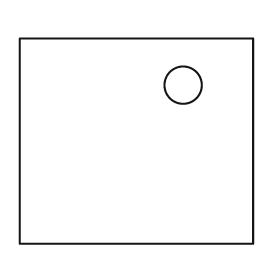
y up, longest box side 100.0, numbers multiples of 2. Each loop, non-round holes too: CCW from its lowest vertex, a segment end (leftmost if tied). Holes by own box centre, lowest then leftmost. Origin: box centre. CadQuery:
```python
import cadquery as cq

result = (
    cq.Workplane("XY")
    .moveTo(-50.0, -44.0)
    .lineTo(50.0, -44.0)
    .lineTo(50.0, 44.0)
    .lineTo(-50.0, 44.0)
    .close()
    .moveTo(20.0, 24.0)
    .circle(8.0)
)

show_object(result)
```